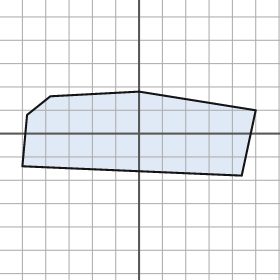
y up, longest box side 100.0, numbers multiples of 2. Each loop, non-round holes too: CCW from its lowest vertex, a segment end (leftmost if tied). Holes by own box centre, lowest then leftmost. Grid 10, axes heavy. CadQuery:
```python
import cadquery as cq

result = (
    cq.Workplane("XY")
    .moveTo(44.0, -18.0)
    .lineTo(50.0, 10.0)
    .lineTo(0.0, 18.0)
    .lineTo(-38.0, 16.0)
    .lineTo(-48.0, 8.0)
    .lineTo(-50.0, -14.0)
    .close()
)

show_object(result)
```